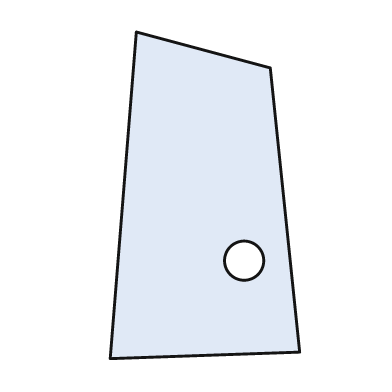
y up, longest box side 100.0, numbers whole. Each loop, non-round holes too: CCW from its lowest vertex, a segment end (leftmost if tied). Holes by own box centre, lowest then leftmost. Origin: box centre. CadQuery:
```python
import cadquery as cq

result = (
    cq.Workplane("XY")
    .moveTo(-29.0, -50.0)
    .lineTo(29.0, -48.0)
    .lineTo(20.0, 39.0)
    .lineTo(-21.0, 50.0)
    .close()
    .moveTo(12.0, -20.0)
    .circle(6.0)
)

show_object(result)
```